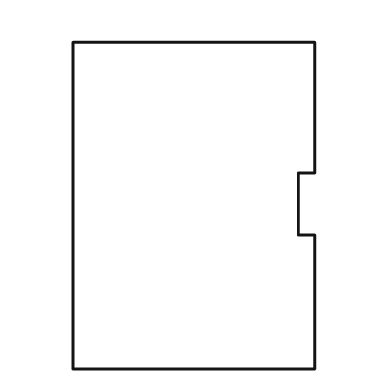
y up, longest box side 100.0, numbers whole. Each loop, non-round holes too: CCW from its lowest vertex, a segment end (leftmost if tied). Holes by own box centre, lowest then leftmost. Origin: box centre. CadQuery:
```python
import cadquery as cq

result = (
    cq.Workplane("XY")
    .moveTo(-37.0, -50.0)
    .lineTo(37.0, -50.0)
    .lineTo(37.0, -9.0)
    .lineTo(32.0, -9.0)
    .lineTo(32.0, 10.0)
    .lineTo(37.0, 10.0)
    .lineTo(37.0, 50.0)
    .lineTo(-37.0, 50.0)
    .close()
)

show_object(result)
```